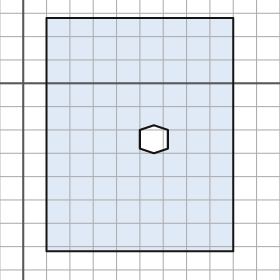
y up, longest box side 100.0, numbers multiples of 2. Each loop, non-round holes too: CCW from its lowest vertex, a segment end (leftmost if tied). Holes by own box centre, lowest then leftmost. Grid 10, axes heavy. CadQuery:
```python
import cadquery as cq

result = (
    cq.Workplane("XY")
    .moveTo(10.0, -72.0)
    .lineTo(90.0, -72.0)
    .lineTo(90.0, 28.0)
    .lineTo(10.0, 28.0)
    .close()
    .moveTo(56.0, -30.0)
    .lineTo(62.0, -28.0)
    .lineTo(62.0, -20.0)
    .lineTo(56.0, -18.0)
    .lineTo(50.0, -20.0)
    .lineTo(50.0, -28.0)
    .close()
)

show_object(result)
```